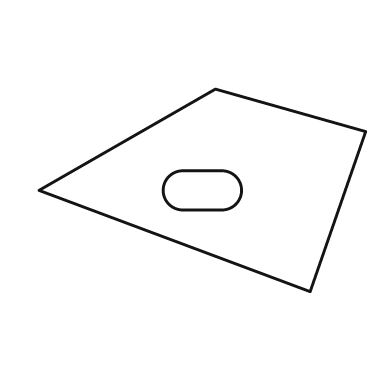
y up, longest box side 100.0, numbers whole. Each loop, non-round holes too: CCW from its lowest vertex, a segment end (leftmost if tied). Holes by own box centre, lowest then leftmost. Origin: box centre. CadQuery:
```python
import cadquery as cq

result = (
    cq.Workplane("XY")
    .moveTo(33.0, -31.0)
    .lineTo(50.0, 18.0)
    .lineTo(4.0, 31.0)
    .lineTo(-50.0, 0.0)
    .close()
    .moveTo(-6.0, -6.0)
    .lineTo(6.0, -6.0)
    .threePointArc((12.0, 0.0), (6.0, 6.0))
    .lineTo(-6.0, 6.0)
    .threePointArc((-12.0, 0.0), (-6.0, -6.0))
    .close()
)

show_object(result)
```